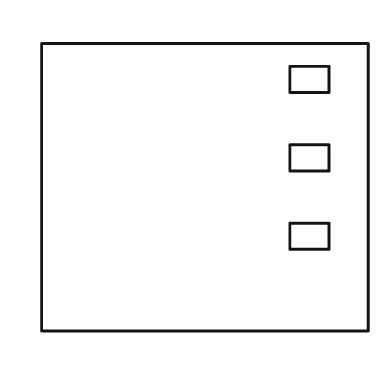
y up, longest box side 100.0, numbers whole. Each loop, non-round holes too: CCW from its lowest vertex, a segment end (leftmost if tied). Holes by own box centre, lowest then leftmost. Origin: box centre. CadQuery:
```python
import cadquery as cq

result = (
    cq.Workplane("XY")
    .moveTo(-50.0, -44.0)
    .lineTo(50.0, -44.0)
    .lineTo(50.0, 44.0)
    .lineTo(-50.0, 44.0)
    .close()
    .moveTo(26.0, -19.0)
    .lineTo(38.0, -19.0)
    .lineTo(38.0, -11.0)
    .lineTo(26.0, -11.0)
    .close()
    .moveTo(26.0, 5.0)
    .lineTo(38.0, 5.0)
    .lineTo(38.0, 13.0)
    .lineTo(26.0, 13.0)
    .close()
    .moveTo(26.0, 29.0)
    .lineTo(38.0, 29.0)
    .lineTo(38.0, 37.0)
    .lineTo(26.0, 37.0)
    .close()
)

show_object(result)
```